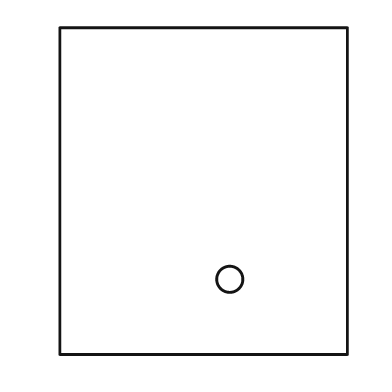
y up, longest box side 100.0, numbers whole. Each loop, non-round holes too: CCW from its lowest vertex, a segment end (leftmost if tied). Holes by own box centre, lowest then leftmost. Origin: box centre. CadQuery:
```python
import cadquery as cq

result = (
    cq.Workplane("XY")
    .moveTo(-44.0, -50.0)
    .lineTo(44.0, -50.0)
    .lineTo(44.0, 50.0)
    .lineTo(-44.0, 50.0)
    .close()
    .moveTo(8.0, -27.0)
    .circle(4.0)
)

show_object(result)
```